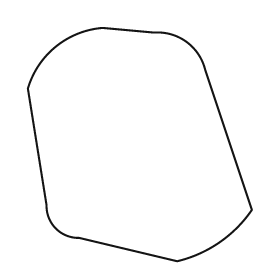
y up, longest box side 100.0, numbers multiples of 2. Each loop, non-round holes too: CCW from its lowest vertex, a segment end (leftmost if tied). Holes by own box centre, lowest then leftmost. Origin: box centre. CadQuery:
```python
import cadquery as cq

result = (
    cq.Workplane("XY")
    .moveTo(16.0, -50.0)
    .threePointArc((34.0, -42.0), (48.0, -28.0))
    .lineTo(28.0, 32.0)
    .threePointArc((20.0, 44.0), (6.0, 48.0))
    .lineTo(-16.0, 50.0)
    .threePointArc((-36.0, 42.0), (-48.0, 24.0))
    .lineTo(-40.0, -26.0)
    .threePointArc((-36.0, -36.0), (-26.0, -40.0))
    .close()
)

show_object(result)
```